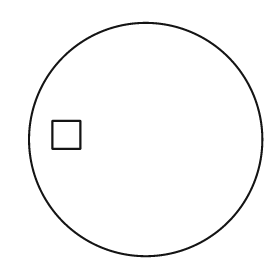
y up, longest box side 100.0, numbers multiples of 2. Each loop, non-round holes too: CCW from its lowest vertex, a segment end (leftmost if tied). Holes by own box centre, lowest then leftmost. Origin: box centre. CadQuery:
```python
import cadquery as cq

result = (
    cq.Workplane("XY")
    .moveTo(0.0, 0.0)
    .circle(50.0)
    .moveTo(-40.0, -4.0)
    .lineTo(-28.0, -4.0)
    .lineTo(-28.0, 8.0)
    .lineTo(-40.0, 8.0)
    .close()
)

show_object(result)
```